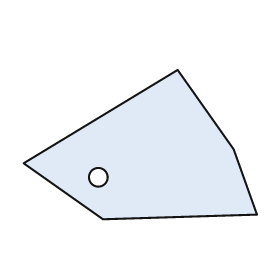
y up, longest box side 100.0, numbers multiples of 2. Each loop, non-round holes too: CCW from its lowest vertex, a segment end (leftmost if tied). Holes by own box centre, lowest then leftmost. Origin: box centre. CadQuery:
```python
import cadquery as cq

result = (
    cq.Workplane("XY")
    .moveTo(-16.0, -32.0)
    .lineTo(50.0, -30.0)
    .lineTo(40.0, -2.0)
    .lineTo(16.0, 32.0)
    .lineTo(-50.0, -8.0)
    .close()
    .moveTo(-18.0, -14.0)
    .circle(4.0)
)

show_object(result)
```